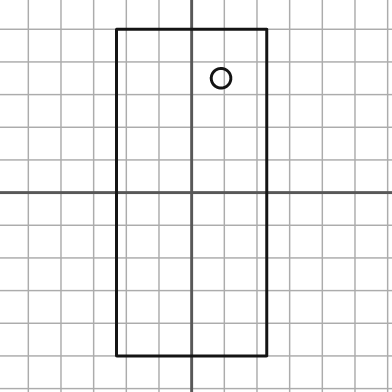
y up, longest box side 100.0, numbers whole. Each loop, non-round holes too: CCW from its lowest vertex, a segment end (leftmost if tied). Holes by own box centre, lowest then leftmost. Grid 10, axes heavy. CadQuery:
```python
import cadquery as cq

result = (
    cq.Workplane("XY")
    .moveTo(-23.0, -50.0)
    .lineTo(23.0, -50.0)
    .lineTo(23.0, 50.0)
    .lineTo(-23.0, 50.0)
    .close()
    .moveTo(9.0, 35.0)
    .circle(3.0)
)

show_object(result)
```